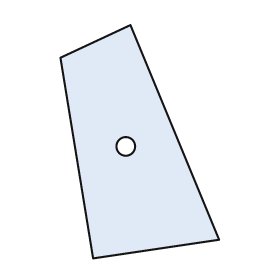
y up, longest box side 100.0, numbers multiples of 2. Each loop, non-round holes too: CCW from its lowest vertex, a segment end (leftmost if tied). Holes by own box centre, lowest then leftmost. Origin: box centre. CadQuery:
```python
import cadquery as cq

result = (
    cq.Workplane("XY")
    .moveTo(-20.0, -50.0)
    .lineTo(34.0, -42.0)
    .lineTo(-4.0, 50.0)
    .lineTo(-34.0, 36.0)
    .close()
    .moveTo(-6.0, -2.0)
    .circle(4.0)
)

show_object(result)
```